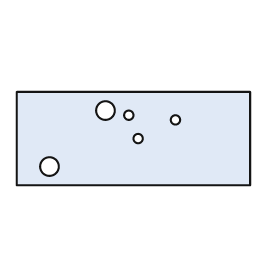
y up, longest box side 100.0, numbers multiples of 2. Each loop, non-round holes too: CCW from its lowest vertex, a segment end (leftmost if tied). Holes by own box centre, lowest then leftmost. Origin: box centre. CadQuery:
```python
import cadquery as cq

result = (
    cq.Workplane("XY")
    .moveTo(-50.0, -20.0)
    .lineTo(50.0, -20.0)
    .lineTo(50.0, 20.0)
    .lineTo(-50.0, 20.0)
    .close()
    .moveTo(-36.0, -12.0)
    .circle(4.0)
    .moveTo(2.0, 0.0)
    .circle(2.0)
    .moveTo(18.0, 8.0)
    .circle(2.0)
    .moveTo(-2.0, 10.0)
    .circle(2.0)
    .moveTo(-12.0, 12.0)
    .circle(4.0)
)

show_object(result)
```